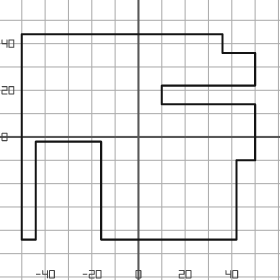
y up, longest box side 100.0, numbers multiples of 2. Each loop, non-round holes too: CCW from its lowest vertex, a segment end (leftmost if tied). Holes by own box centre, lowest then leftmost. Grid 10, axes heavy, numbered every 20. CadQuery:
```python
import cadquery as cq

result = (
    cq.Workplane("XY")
    .moveTo(-50.0, -44.0)
    .lineTo(-44.0, -44.0)
    .lineTo(-44.0, -2.0)
    .lineTo(-16.0, -2.0)
    .lineTo(-16.0, -44.0)
    .lineTo(42.0, -44.0)
    .lineTo(42.0, -10.0)
    .lineTo(50.0, -10.0)
    .lineTo(50.0, 14.0)
    .lineTo(10.0, 14.0)
    .lineTo(10.0, 22.0)
    .lineTo(50.0, 22.0)
    .lineTo(50.0, 36.0)
    .lineTo(36.0, 36.0)
    .lineTo(36.0, 44.0)
    .lineTo(-50.0, 44.0)
    .close()
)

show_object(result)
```